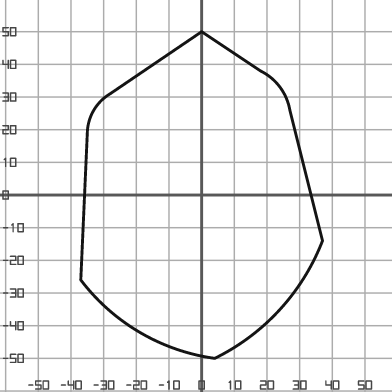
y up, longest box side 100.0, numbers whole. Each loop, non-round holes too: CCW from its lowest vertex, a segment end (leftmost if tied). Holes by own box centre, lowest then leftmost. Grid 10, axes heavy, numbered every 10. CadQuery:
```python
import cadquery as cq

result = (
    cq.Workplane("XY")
    .moveTo(4.0, -50.0)
    .threePointArc((24.0, -35.0), (37.0, -14.0))
    .lineTo(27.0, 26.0)
    .threePointArc((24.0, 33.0), (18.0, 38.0))
    .lineTo(0.0, 50.0)
    .lineTo(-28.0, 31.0)
    .threePointArc((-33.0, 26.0), (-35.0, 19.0))
    .lineTo(-37.0, -26.0)
    .threePointArc((-19.0, -42.0), (4.0, -50.0))
    .close()
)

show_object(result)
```